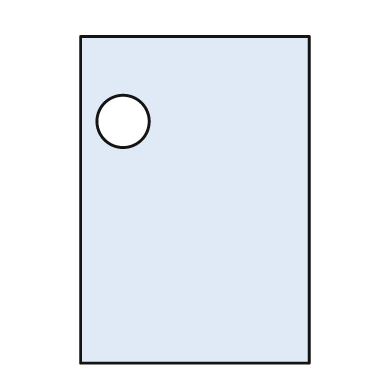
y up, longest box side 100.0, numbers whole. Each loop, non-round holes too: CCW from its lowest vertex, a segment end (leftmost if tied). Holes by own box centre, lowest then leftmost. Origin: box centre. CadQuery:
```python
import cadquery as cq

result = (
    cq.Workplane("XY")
    .moveTo(-35.0, -50.0)
    .lineTo(35.0, -50.0)
    .lineTo(35.0, 50.0)
    .lineTo(-35.0, 50.0)
    .close()
    .moveTo(-22.0, 24.0)
    .circle(8.0)
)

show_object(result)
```